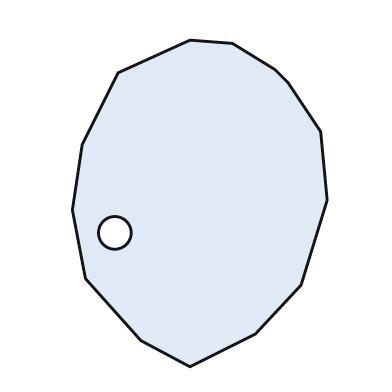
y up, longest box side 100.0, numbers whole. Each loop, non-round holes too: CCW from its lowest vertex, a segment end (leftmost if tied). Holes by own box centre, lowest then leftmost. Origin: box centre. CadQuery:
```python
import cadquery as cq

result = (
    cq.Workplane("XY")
    .moveTo(-3.0, -50.0)
    .lineTo(17.0, -40.0)
    .lineTo(31.0, -25.0)
    .lineTo(39.0, 1.0)
    .lineTo(37.0, 22.0)
    .lineTo(27.0, 37.0)
    .lineTo(23.0, 41.0)
    .lineTo(10.0, 49.0)
    .lineTo(-3.0, 50.0)
    .lineTo(-25.0, 40.0)
    .lineTo(-36.0, 18.0)
    .lineTo(-39.0, -2.0)
    .lineTo(-35.0, -23.0)
    .lineTo(-18.0, -42.0)
    .close()
    .moveTo(-26.0, -9.0)
    .circle(5.0)
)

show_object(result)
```